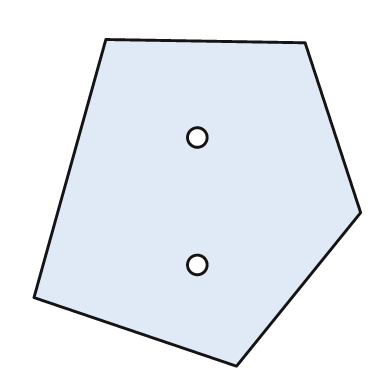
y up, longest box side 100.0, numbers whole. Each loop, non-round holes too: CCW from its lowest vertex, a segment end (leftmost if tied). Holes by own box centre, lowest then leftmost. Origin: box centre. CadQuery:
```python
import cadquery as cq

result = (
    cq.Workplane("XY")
    .moveTo(12.0, -50.0)
    .lineTo(50.0, -3.0)
    .lineTo(33.0, 49.0)
    .lineTo(-28.0, 50.0)
    .lineTo(-50.0, -29.0)
    .close()
    .moveTo(0.0, -19.0)
    .circle(3.0)
    .moveTo(0.0, 20.0)
    .circle(3.0)
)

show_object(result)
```